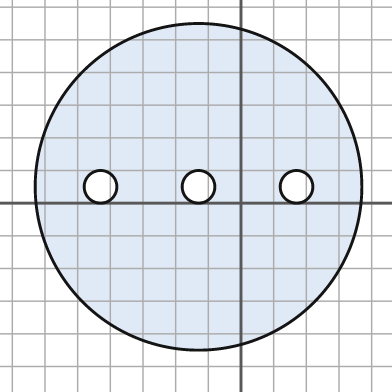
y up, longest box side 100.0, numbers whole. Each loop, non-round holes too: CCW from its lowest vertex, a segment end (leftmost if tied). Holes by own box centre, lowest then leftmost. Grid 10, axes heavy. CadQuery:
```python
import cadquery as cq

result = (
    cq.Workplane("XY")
    .moveTo(-13.0, 5.0)
    .circle(50.0)
    .moveTo(-43.0, 5.0)
    .circle(5.0)
    .moveTo(-13.0, 5.0)
    .circle(5.0)
    .moveTo(17.0, 5.0)
    .circle(5.0)
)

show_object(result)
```